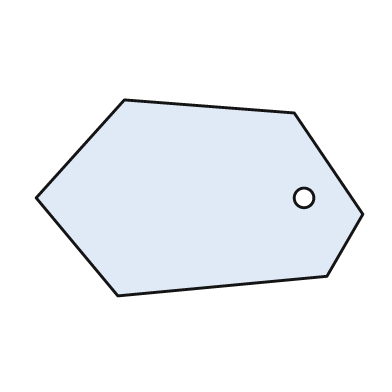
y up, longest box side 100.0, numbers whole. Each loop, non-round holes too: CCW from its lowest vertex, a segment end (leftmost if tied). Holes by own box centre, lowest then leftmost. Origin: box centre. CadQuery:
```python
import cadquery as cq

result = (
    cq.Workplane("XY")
    .moveTo(-25.0, -30.0)
    .lineTo(39.0, -24.0)
    .lineTo(50.0, -5.0)
    .lineTo(29.0, 26.0)
    .lineTo(-23.0, 30.0)
    .lineTo(-50.0, 0.0)
    .close()
    .moveTo(32.0, 0.0)
    .circle(3.0)
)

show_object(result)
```